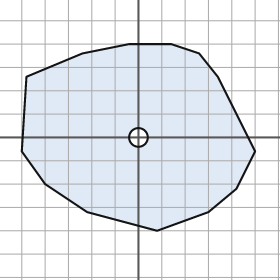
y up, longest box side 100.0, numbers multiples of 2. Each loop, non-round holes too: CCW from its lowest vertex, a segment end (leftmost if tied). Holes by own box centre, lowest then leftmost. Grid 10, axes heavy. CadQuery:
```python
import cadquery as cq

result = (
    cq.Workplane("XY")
    .moveTo(8.0, -40.0)
    .lineTo(30.0, -32.0)
    .lineTo(42.0, -22.0)
    .lineTo(50.0, -6.0)
    .lineTo(34.0, 26.0)
    .lineTo(26.0, 36.0)
    .lineTo(14.0, 40.0)
    .lineTo(-4.0, 40.0)
    .lineTo(-24.0, 36.0)
    .lineTo(-48.0, 26.0)
    .lineTo(-50.0, -6.0)
    .lineTo(-40.0, -20.0)
    .lineTo(-22.0, -32.0)
    .close()
    .moveTo(0.0, 0.0)
    .circle(4.0)
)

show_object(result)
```